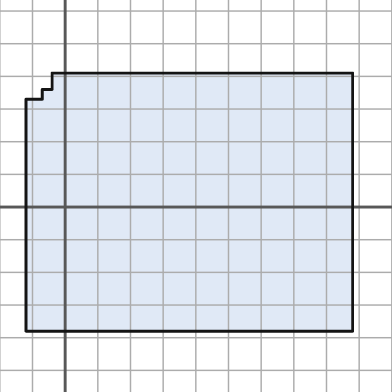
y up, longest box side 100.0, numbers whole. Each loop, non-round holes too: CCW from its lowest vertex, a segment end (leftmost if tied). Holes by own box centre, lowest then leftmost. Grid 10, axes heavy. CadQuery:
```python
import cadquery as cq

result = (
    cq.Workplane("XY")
    .moveTo(-12.0, -38.0)
    .lineTo(88.0, -38.0)
    .lineTo(88.0, 41.0)
    .lineTo(-4.0, 41.0)
    .lineTo(-4.0, 36.0)
    .lineTo(-7.0, 36.0)
    .lineTo(-7.0, 33.0)
    .lineTo(-12.0, 33.0)
    .close()
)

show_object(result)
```